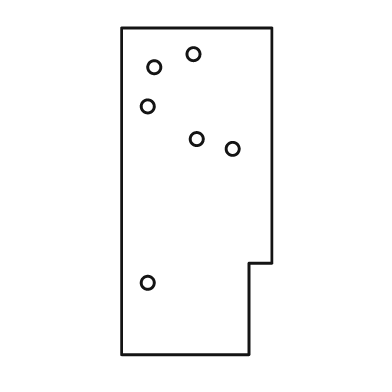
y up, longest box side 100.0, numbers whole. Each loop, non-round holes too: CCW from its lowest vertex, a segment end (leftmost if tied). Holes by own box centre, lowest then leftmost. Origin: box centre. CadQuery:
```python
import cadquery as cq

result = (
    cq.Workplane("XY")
    .moveTo(-23.0, -50.0)
    .lineTo(16.0, -50.0)
    .lineTo(16.0, -22.0)
    .lineTo(23.0, -22.0)
    .lineTo(23.0, 50.0)
    .lineTo(-23.0, 50.0)
    .close()
    .moveTo(-15.0, -28.0)
    .circle(2.0)
    .moveTo(11.0, 13.0)
    .circle(2.0)
    .moveTo(0.0, 16.0)
    .circle(2.0)
    .moveTo(-15.0, 26.0)
    .circle(2.0)
    .moveTo(-13.0, 38.0)
    .circle(2.0)
    .moveTo(-1.0, 42.0)
    .circle(2.0)
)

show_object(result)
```